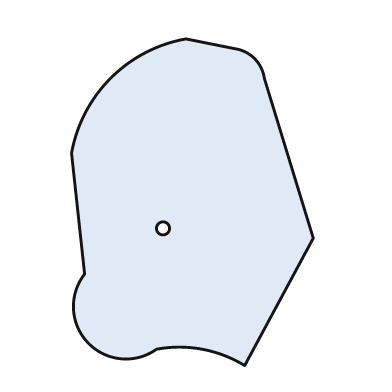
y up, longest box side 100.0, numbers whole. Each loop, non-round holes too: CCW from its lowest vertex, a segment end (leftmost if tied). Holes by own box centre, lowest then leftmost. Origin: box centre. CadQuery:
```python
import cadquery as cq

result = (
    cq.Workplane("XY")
    .moveTo(16.0, -50.0)
    .lineTo(37.0, -11.0)
    .lineTo(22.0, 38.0)
    .threePointArc((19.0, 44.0), (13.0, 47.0))
    .lineTo(-2.0, 50.0)
    .threePointArc((-25.0, 38.0), (-37.0, 15.0))
    .lineTo(-33.0, -22.0)
    .threePointArc((-32.0, -43.0), (-11.0, -45.0))
    .threePointArc((3.0, -45.0), (16.0, -50.0))
    .close()
    .moveTo(-9.0, -8.0)
    .circle(2.0)
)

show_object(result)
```